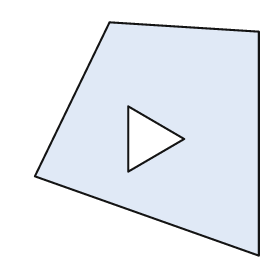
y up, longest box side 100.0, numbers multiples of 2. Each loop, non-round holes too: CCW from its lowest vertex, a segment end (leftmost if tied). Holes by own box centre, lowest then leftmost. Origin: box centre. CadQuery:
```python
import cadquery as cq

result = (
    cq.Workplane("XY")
    .moveTo(48.0, -50.0)
    .lineTo(48.0, 46.0)
    .lineTo(-16.0, 50.0)
    .lineTo(-48.0, -16.0)
    .close()
    .moveTo(-8.0, -14.0)
    .lineTo(16.0, 0.0)
    .lineTo(-8.0, 14.0)
    .close()
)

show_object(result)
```